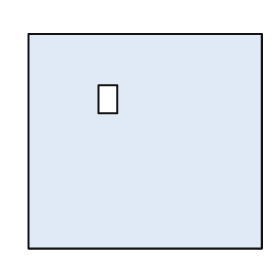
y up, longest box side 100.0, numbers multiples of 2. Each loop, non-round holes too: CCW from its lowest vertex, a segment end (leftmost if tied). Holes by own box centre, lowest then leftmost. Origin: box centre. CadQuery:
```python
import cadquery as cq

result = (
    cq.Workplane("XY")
    .moveTo(-50.0, -46.0)
    .lineTo(50.0, -46.0)
    .lineTo(50.0, 46.0)
    .lineTo(-50.0, 46.0)
    .close()
    .moveTo(-20.0, 12.0)
    .lineTo(-12.0, 12.0)
    .lineTo(-12.0, 24.0)
    .lineTo(-20.0, 24.0)
    .close()
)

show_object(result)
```